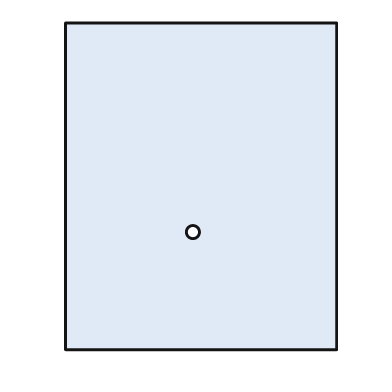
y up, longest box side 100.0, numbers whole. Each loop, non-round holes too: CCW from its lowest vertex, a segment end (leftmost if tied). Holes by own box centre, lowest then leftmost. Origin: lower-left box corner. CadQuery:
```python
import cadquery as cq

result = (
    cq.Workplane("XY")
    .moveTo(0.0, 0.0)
    .lineTo(83.0, 0.0)
    .lineTo(83.0, 100.0)
    .lineTo(0.0, 100.0)
    .close()
    .moveTo(39.0, 36.0)
    .circle(2.0)
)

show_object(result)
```